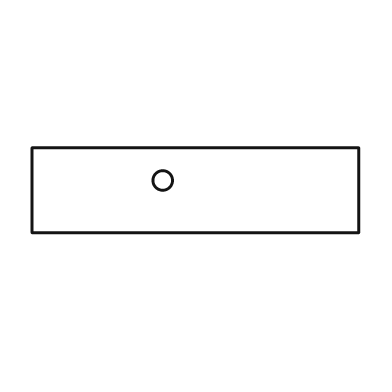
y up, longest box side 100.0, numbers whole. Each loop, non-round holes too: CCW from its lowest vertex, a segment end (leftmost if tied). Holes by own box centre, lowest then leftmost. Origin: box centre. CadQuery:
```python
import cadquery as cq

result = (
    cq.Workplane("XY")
    .moveTo(-50.0, -13.0)
    .lineTo(50.0, -13.0)
    .lineTo(50.0, 13.0)
    .lineTo(-50.0, 13.0)
    .close()
    .moveTo(-10.0, 3.0)
    .circle(3.0)
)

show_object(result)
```